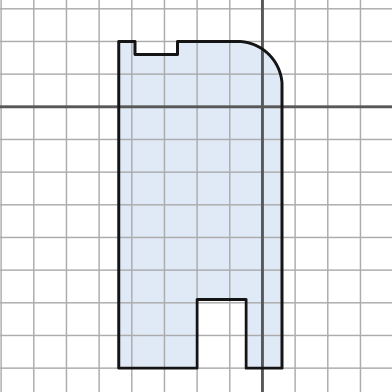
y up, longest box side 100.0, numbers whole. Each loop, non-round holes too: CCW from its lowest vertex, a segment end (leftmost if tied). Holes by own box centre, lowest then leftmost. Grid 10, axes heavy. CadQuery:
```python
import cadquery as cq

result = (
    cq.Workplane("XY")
    .moveTo(-44.0, -80.0)
    .lineTo(-20.0, -80.0)
    .lineTo(-20.0, -59.0)
    .lineTo(-5.0, -59.0)
    .lineTo(-5.0, -80.0)
    .lineTo(6.0, -80.0)
    .lineTo(6.0, 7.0)
    .threePointArc((2.0, 16.0), (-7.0, 20.0))
    .lineTo(-26.0, 20.0)
    .lineTo(-26.0, 16.0)
    .lineTo(-39.0, 16.0)
    .lineTo(-39.0, 20.0)
    .lineTo(-44.0, 20.0)
    .close()
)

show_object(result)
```